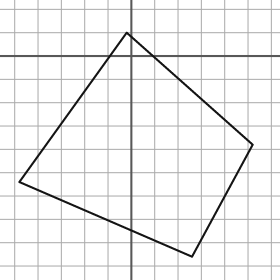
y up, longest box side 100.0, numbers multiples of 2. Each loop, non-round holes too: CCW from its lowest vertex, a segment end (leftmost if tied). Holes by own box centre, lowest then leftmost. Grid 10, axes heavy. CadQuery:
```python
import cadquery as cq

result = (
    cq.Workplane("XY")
    .moveTo(26.0, -86.0)
    .lineTo(52.0, -38.0)
    .lineTo(-2.0, 10.0)
    .lineTo(-48.0, -54.0)
    .close()
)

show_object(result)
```